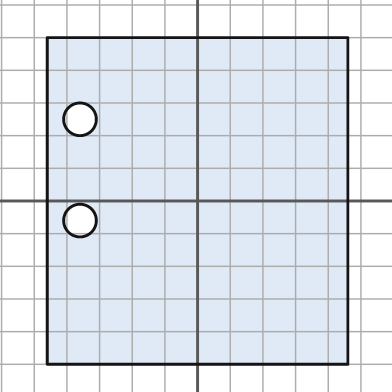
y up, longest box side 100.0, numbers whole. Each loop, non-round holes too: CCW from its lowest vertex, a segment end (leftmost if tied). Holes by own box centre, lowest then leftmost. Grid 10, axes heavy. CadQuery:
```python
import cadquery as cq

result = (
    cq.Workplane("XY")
    .moveTo(-46.0, -50.0)
    .lineTo(46.0, -50.0)
    .lineTo(46.0, 50.0)
    .lineTo(-46.0, 50.0)
    .close()
    .moveTo(-36.0, -6.0)
    .circle(5.0)
    .moveTo(-36.0, 25.0)
    .circle(5.0)
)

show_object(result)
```